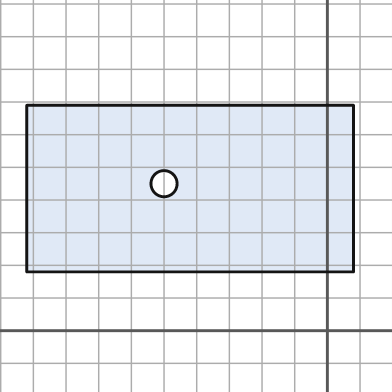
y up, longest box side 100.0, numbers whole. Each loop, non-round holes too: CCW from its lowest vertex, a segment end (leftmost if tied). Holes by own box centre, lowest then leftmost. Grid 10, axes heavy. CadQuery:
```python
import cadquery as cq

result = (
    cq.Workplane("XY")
    .moveTo(-92.0, 18.0)
    .lineTo(8.0, 18.0)
    .lineTo(8.0, 69.0)
    .lineTo(-92.0, 69.0)
    .close()
    .moveTo(-50.0, 45.0)
    .circle(4.0)
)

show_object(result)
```